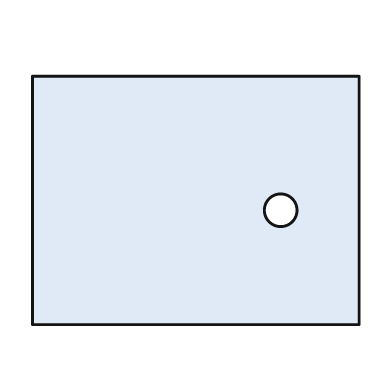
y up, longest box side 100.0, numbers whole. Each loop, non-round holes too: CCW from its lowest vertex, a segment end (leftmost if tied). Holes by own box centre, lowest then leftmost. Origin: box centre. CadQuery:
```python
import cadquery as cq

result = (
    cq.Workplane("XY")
    .moveTo(-50.0, -38.0)
    .lineTo(50.0, -38.0)
    .lineTo(50.0, 38.0)
    .lineTo(-50.0, 38.0)
    .close()
    .moveTo(26.0, -3.0)
    .circle(5.0)
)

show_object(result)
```